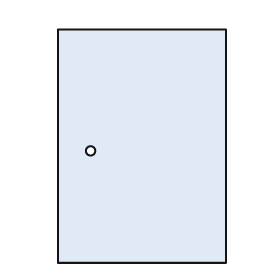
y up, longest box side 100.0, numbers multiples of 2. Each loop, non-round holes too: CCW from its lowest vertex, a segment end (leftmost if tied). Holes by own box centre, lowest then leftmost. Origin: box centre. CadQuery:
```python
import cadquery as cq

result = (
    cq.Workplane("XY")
    .moveTo(-36.0, -50.0)
    .lineTo(36.0, -50.0)
    .lineTo(36.0, 50.0)
    .lineTo(-36.0, 50.0)
    .close()
    .moveTo(-22.0, -2.0)
    .circle(2.0)
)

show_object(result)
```